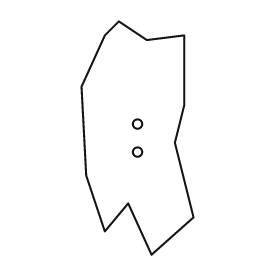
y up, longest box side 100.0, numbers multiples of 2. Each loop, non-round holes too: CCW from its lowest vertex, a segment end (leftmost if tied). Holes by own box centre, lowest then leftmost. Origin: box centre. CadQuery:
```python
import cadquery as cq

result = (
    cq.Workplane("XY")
    .moveTo(6.0, -50.0)
    .lineTo(24.0, -34.0)
    .lineTo(16.0, -2.0)
    .lineTo(20.0, 14.0)
    .lineTo(20.0, 44.0)
    .lineTo(4.0, 42.0)
    .lineTo(-8.0, 50.0)
    .lineTo(-14.0, 44.0)
    .lineTo(-24.0, 22.0)
    .lineTo(-22.0, -16.0)
    .lineTo(-14.0, -40.0)
    .lineTo(-4.0, -28.0)
    .close()
    .moveTo(0.0, -6.0)
    .circle(2.0)
    .moveTo(0.0, 6.0)
    .circle(2.0)
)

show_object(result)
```